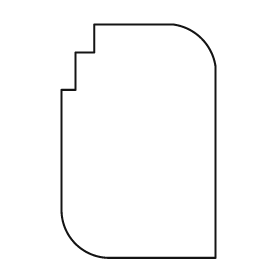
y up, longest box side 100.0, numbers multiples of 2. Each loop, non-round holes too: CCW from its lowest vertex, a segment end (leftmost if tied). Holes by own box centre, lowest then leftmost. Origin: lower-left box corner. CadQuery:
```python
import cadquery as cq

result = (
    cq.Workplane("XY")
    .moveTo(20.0, 0.0)
    .lineTo(66.0, 0.0)
    .lineTo(66.0, 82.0)
    .threePointArc((60.0, 94.0), (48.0, 100.0))
    .lineTo(14.0, 100.0)
    .lineTo(14.0, 88.0)
    .lineTo(6.0, 88.0)
    .lineTo(6.0, 72.0)
    .lineTo(0.0, 72.0)
    .lineTo(0.0, 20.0)
    .threePointArc((6.0, 6.0), (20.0, 0.0))
    .close()
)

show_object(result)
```